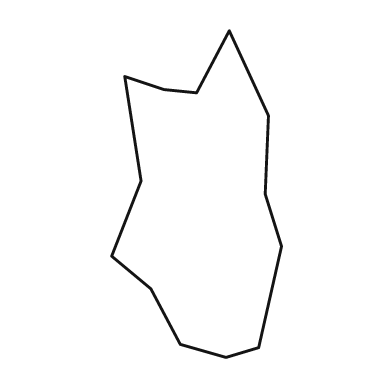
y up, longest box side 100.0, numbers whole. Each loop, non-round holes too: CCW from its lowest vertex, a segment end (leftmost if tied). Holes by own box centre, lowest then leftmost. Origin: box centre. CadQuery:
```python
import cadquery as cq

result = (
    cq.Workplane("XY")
    .moveTo(9.0, -50.0)
    .lineTo(19.0, -47.0)
    .lineTo(26.0, -16.0)
    .lineTo(21.0, 0.0)
    .lineTo(22.0, 24.0)
    .lineTo(10.0, 50.0)
    .lineTo(0.0, 31.0)
    .lineTo(-10.0, 32.0)
    .lineTo(-22.0, 36.0)
    .lineTo(-17.0, 4.0)
    .lineTo(-26.0, -19.0)
    .lineTo(-14.0, -29.0)
    .lineTo(-5.0, -46.0)
    .close()
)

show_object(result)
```